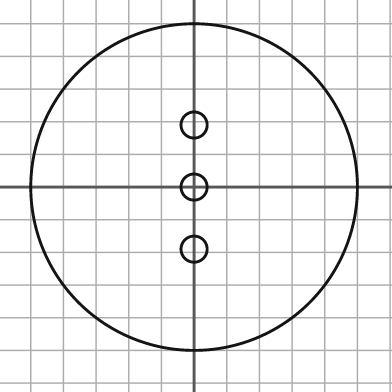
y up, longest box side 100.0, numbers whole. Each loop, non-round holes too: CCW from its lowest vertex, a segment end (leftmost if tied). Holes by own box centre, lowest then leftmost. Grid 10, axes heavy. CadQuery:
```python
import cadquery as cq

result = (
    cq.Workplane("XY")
    .moveTo(0.0, 0.0)
    .circle(50.0)
    .moveTo(0.0, -19.0)
    .circle(4.0)
    .moveTo(0.0, 0.0)
    .circle(4.0)
    .moveTo(0.0, 19.0)
    .circle(4.0)
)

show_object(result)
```